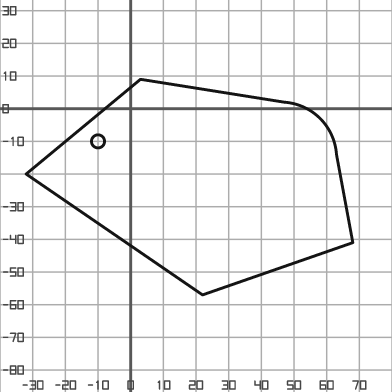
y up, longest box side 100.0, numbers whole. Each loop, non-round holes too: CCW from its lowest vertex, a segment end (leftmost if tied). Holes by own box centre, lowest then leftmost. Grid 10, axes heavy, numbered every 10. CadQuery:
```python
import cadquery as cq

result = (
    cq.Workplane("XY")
    .moveTo(22.0, -57.0)
    .lineTo(68.0, -41.0)
    .lineTo(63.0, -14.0)
    .threePointArc((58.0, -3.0), (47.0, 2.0))
    .lineTo(3.0, 9.0)
    .lineTo(-32.0, -20.0)
    .close()
    .moveTo(-10.0, -10.0)
    .circle(2.0)
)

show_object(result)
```